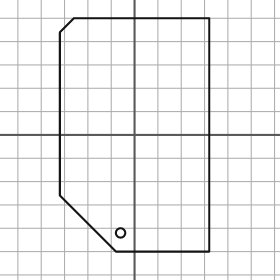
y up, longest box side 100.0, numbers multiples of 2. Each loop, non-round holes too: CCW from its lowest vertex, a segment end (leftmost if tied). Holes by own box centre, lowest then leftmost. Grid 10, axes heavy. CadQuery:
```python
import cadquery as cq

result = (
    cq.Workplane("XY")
    .moveTo(-8.0, -50.0)
    .lineTo(32.0, -50.0)
    .lineTo(32.0, 50.0)
    .lineTo(-26.0, 50.0)
    .lineTo(-32.0, 44.0)
    .lineTo(-32.0, -26.0)
    .close()
    .moveTo(-6.0, -42.0)
    .circle(2.0)
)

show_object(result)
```